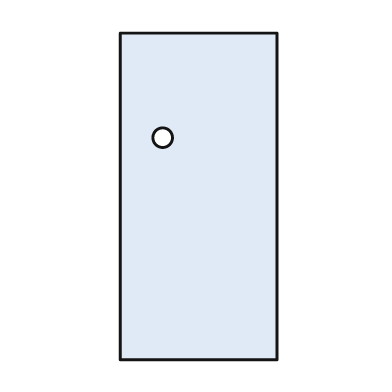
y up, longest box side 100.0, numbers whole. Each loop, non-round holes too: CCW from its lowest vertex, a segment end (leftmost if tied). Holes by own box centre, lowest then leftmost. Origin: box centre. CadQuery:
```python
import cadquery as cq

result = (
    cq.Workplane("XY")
    .moveTo(-24.0, -50.0)
    .lineTo(24.0, -50.0)
    .lineTo(24.0, 50.0)
    .lineTo(-24.0, 50.0)
    .close()
    .moveTo(-11.0, 18.0)
    .circle(3.0)
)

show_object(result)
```